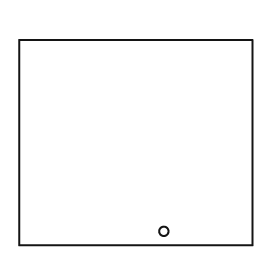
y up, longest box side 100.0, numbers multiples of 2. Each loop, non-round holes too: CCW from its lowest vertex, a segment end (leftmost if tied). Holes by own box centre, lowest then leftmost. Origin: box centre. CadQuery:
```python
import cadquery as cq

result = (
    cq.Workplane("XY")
    .moveTo(-50.0, -44.0)
    .lineTo(50.0, -44.0)
    .lineTo(50.0, 44.0)
    .lineTo(-50.0, 44.0)
    .close()
    .moveTo(12.0, -38.0)
    .circle(2.0)
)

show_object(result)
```